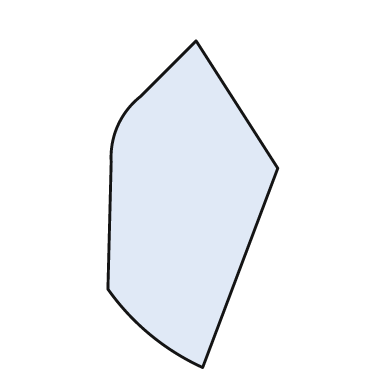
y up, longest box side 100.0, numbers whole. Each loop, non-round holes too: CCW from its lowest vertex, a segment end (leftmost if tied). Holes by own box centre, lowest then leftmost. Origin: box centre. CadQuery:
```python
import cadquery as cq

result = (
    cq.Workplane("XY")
    .moveTo(3.0, -50.0)
    .lineTo(26.0, 11.0)
    .lineTo(1.0, 50.0)
    .lineTo(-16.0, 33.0)
    .threePointArc((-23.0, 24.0), (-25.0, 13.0))
    .lineTo(-26.0, -26.0)
    .threePointArc((-13.0, -40.0), (3.0, -50.0))
    .close()
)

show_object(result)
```